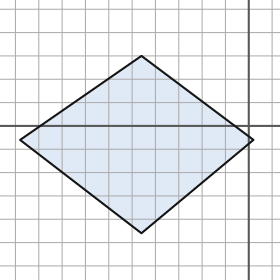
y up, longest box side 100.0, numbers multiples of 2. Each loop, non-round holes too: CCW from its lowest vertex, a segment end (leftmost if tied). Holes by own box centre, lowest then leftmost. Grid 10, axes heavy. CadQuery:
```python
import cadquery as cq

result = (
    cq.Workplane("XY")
    .moveTo(-46.0, -46.0)
    .lineTo(2.0, -6.0)
    .lineTo(-46.0, 30.0)
    .lineTo(-98.0, -6.0)
    .close()
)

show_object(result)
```